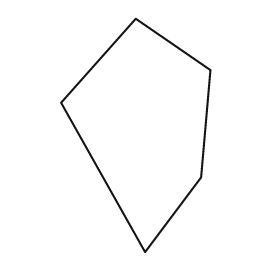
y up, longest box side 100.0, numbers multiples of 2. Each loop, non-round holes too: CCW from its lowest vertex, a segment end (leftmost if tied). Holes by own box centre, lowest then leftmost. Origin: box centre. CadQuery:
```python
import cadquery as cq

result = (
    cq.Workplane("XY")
    .moveTo(4.0, -50.0)
    .lineTo(28.0, -18.0)
    .lineTo(32.0, 28.0)
    .lineTo(0.0, 50.0)
    .lineTo(-32.0, 14.0)
    .close()
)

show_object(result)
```